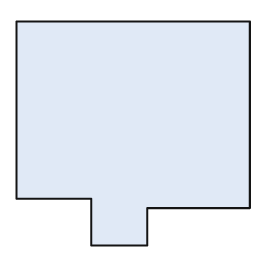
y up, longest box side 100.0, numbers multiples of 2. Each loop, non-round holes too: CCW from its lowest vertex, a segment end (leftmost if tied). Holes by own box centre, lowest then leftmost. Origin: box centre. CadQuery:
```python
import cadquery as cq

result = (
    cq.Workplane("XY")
    .moveTo(-18.0, -48.0)
    .lineTo(6.0, -48.0)
    .lineTo(6.0, -32.0)
    .lineTo(50.0, -32.0)
    .lineTo(50.0, 48.0)
    .lineTo(-50.0, 48.0)
    .lineTo(-50.0, -28.0)
    .lineTo(-18.0, -28.0)
    .close()
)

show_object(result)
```